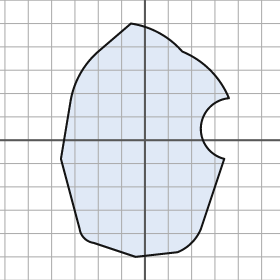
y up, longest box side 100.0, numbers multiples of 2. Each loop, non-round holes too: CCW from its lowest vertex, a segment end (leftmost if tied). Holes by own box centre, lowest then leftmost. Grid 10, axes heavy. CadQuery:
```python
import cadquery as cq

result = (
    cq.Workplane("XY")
    .moveTo(-4.0, -50.0)
    .lineTo(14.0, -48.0)
    .threePointArc((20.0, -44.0), (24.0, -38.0))
    .lineTo(34.0, -8.0)
    .threePointArc((24.0, 6.0), (36.0, 18.0))
    .threePointArc((28.0, 30.0), (16.0, 38.0))
    .threePointArc((6.0, 46.0), (-6.0, 50.0))
    .lineTo(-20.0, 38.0)
    .threePointArc((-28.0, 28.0), (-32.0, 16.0))
    .lineTo(-36.0, -8.0)
    .lineTo(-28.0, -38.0)
    .threePointArc((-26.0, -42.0), (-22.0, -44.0))
    .close()
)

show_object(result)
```